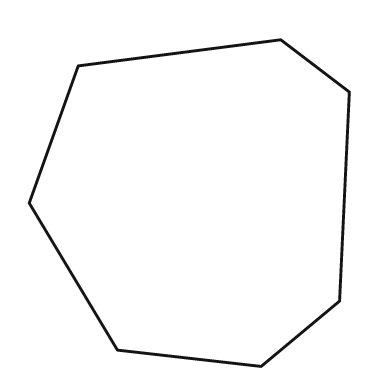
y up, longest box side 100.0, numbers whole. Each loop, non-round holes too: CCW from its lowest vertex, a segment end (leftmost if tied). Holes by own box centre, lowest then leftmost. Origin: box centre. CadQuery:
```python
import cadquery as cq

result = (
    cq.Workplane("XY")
    .moveTo(22.0, -50.0)
    .lineTo(46.0, -30.0)
    .lineTo(49.0, 34.0)
    .lineTo(28.0, 50.0)
    .lineTo(-34.0, 42.0)
    .lineTo(-49.0, 0.0)
    .lineTo(-22.0, -45.0)
    .close()
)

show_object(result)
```